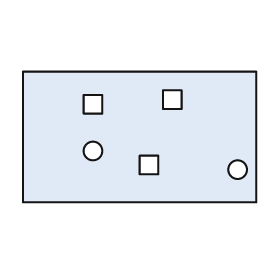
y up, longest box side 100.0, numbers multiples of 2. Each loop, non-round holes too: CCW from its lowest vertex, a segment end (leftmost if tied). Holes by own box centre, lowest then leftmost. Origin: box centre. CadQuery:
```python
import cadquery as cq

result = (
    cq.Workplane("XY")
    .moveTo(-50.0, -28.0)
    .lineTo(50.0, -28.0)
    .lineTo(50.0, 28.0)
    .lineTo(-50.0, 28.0)
    .close()
    .moveTo(42.0, -14.0)
    .circle(4.0)
    .moveTo(0.0, -16.0)
    .lineTo(8.0, -16.0)
    .lineTo(8.0, -8.0)
    .lineTo(0.0, -8.0)
    .close()
    .moveTo(-20.0, -6.0)
    .circle(4.0)
    .moveTo(-24.0, 10.0)
    .lineTo(-16.0, 10.0)
    .lineTo(-16.0, 18.0)
    .lineTo(-24.0, 18.0)
    .close()
    .moveTo(10.0, 12.0)
    .lineTo(18.0, 12.0)
    .lineTo(18.0, 20.0)
    .lineTo(10.0, 20.0)
    .close()
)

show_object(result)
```